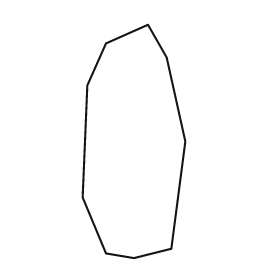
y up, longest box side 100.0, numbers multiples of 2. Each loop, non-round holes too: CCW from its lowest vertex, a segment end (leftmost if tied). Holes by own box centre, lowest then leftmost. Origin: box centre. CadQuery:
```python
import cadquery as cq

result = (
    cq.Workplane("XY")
    .moveTo(0.0, -50.0)
    .lineTo(16.0, -46.0)
    .lineTo(22.0, 0.0)
    .lineTo(14.0, 36.0)
    .lineTo(6.0, 50.0)
    .lineTo(-12.0, 42.0)
    .lineTo(-20.0, 24.0)
    .lineTo(-22.0, -24.0)
    .lineTo(-12.0, -48.0)
    .close()
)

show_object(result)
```